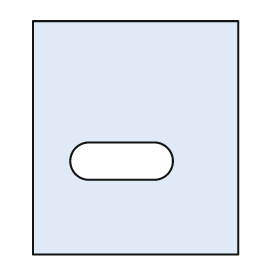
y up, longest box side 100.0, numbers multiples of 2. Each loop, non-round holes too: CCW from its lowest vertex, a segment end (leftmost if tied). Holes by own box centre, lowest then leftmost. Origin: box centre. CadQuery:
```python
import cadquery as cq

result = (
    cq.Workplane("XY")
    .moveTo(-44.0, -50.0)
    .lineTo(44.0, -50.0)
    .lineTo(44.0, 50.0)
    .lineTo(-44.0, 50.0)
    .close()
    .moveTo(-20.0, -18.0)
    .lineTo(8.0, -18.0)
    .threePointArc((16.0, -10.0), (8.0, -2.0))
    .lineTo(-20.0, -2.0)
    .threePointArc((-28.0, -10.0), (-20.0, -18.0))
    .close()
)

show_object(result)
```